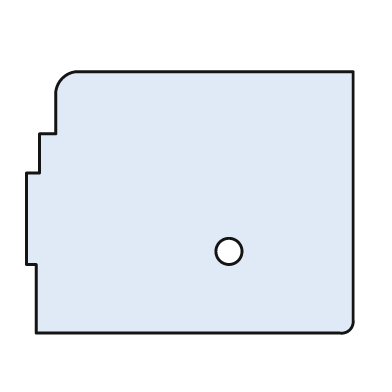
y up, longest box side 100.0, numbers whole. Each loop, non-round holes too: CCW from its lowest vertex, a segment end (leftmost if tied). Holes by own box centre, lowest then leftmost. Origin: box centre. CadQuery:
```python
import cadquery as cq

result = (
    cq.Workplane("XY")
    .moveTo(-47.0, -40.0)
    .lineTo(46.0, -40.0)
    .threePointArc((49.0, -39.0), (50.0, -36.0))
    .lineTo(50.0, 40.0)
    .lineTo(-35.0, 40.0)
    .threePointArc((-39.0, 38.0), (-41.0, 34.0))
    .lineTo(-41.0, 21.0)
    .lineTo(-46.0, 21.0)
    .lineTo(-46.0, 9.0)
    .lineTo(-50.0, 9.0)
    .lineTo(-50.0, -19.0)
    .lineTo(-47.0, -19.0)
    .close()
    .moveTo(12.0, -15.0)
    .circle(4.0)
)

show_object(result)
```